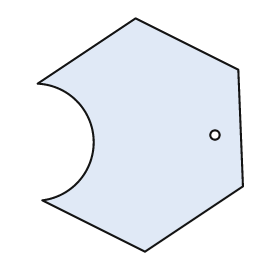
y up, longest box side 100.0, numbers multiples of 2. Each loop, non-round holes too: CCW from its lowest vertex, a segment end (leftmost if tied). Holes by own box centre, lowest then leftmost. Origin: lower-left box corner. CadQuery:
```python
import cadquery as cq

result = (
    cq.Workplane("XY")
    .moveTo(46.0, 0.0)
    .lineTo(88.0, 28.0)
    .lineTo(86.0, 78.0)
    .lineTo(42.0, 100.0)
    .lineTo(0.0, 72.0)
    .threePointArc((24.0, 48.0), (2.0, 22.0))
    .close()
    .moveTo(76.0, 50.0)
    .circle(2.0)
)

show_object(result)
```